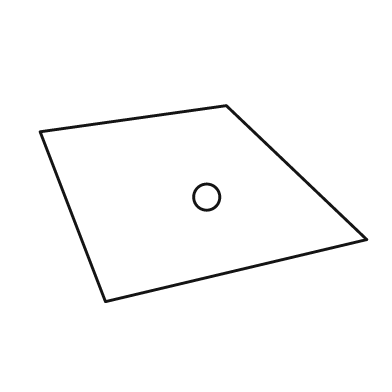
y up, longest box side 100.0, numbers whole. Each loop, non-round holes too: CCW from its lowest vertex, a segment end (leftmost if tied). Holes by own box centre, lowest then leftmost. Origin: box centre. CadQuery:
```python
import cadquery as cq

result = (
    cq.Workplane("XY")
    .moveTo(-30.0, -30.0)
    .lineTo(50.0, -11.0)
    .lineTo(7.0, 30.0)
    .lineTo(-50.0, 22.0)
    .close()
    .moveTo(1.0, 2.0)
    .circle(4.0)
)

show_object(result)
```